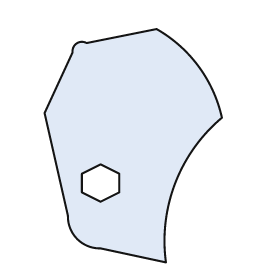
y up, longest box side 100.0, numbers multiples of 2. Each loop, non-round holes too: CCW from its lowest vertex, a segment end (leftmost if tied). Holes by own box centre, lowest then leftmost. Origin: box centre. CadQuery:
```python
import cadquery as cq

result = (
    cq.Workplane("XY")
    .moveTo(14.0, -50.0)
    .threePointArc((18.0, -16.0), (38.0, 12.0))
    .threePointArc((28.0, 34.0), (10.0, 50.0))
    .lineTo(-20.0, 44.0)
    .threePointArc((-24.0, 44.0), (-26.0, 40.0))
    .lineTo(-38.0, 14.0)
    .lineTo(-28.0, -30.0)
    .threePointArc((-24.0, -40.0), (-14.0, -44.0))
    .close()
    .moveTo(-14.0, -24.0)
    .lineTo(-6.0, -20.0)
    .lineTo(-6.0, -12.0)
    .lineTo(-14.0, -8.0)
    .lineTo(-22.0, -12.0)
    .lineTo(-22.0, -20.0)
    .close()
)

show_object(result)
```